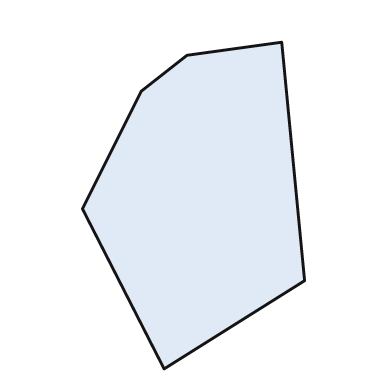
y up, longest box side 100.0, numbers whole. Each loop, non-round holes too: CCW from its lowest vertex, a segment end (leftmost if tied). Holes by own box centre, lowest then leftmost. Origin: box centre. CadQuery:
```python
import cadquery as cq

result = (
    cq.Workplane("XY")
    .moveTo(-9.0, -50.0)
    .lineTo(34.0, -23.0)
    .lineTo(27.0, 50.0)
    .lineTo(-2.0, 46.0)
    .lineTo(-16.0, 35.0)
    .lineTo(-34.0, -1.0)
    .close()
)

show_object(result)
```